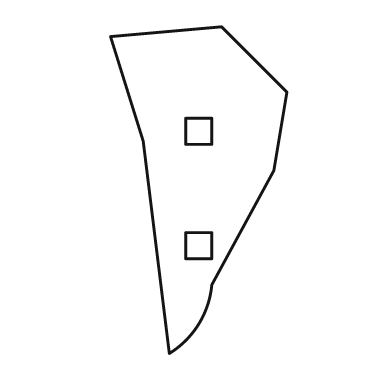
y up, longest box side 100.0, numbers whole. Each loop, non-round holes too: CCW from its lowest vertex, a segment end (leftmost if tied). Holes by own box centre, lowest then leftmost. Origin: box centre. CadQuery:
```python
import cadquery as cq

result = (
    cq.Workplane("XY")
    .moveTo(-9.0, -50.0)
    .threePointArc((0.0, -41.0), (4.0, -29.0))
    .lineTo(23.0, 6.0)
    .lineTo(27.0, 30.0)
    .lineTo(7.0, 50.0)
    .lineTo(-27.0, 47.0)
    .lineTo(-17.0, 15.0)
    .close()
    .moveTo(-4.0, -21.0)
    .lineTo(4.0, -21.0)
    .lineTo(4.0, -13.0)
    .lineTo(-4.0, -13.0)
    .close()
    .moveTo(-4.0, 14.0)
    .lineTo(4.0, 14.0)
    .lineTo(4.0, 22.0)
    .lineTo(-4.0, 22.0)
    .close()
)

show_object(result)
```